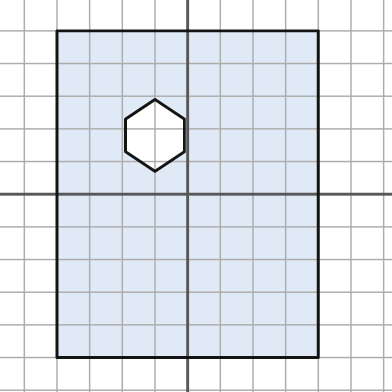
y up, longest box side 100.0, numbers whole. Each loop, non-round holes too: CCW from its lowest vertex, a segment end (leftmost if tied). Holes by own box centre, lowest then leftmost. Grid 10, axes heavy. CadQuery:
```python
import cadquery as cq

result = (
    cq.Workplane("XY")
    .moveTo(-40.0, -50.0)
    .lineTo(40.0, -50.0)
    .lineTo(40.0, 50.0)
    .lineTo(-40.0, 50.0)
    .close()
    .moveTo(-10.0, 7.0)
    .lineTo(-1.0, 13.0)
    .lineTo(-1.0, 23.0)
    .lineTo(-10.0, 29.0)
    .lineTo(-19.0, 23.0)
    .lineTo(-19.0, 13.0)
    .close()
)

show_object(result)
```